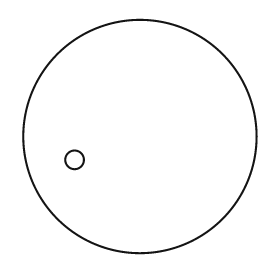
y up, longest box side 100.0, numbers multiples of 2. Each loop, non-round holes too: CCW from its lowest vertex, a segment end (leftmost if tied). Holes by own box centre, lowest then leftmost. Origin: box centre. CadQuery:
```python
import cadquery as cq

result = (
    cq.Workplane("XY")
    .moveTo(0.0, 0.0)
    .circle(50.0)
    .moveTo(-28.0, -10.0)
    .circle(4.0)
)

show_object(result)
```